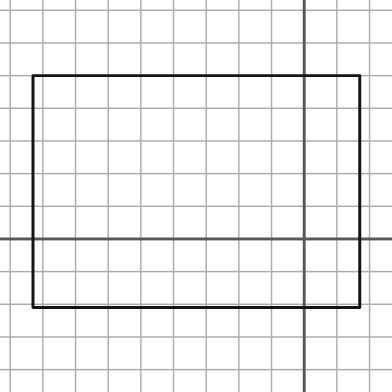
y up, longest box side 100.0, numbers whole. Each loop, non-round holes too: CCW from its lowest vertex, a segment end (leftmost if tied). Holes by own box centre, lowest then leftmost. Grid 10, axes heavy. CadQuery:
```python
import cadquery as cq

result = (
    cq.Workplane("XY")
    .moveTo(-83.0, -21.0)
    .lineTo(17.0, -21.0)
    .lineTo(17.0, 50.0)
    .lineTo(-83.0, 50.0)
    .close()
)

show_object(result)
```